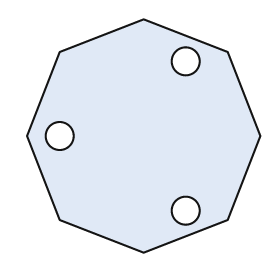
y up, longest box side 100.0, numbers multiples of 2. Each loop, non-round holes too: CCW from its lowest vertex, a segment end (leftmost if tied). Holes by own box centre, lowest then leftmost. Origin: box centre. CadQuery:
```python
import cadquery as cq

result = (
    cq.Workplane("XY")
    .moveTo(0.0, -50.0)
    .lineTo(36.0, -36.0)
    .lineTo(50.0, 0.0)
    .lineTo(36.0, 36.0)
    .lineTo(0.0, 50.0)
    .lineTo(-36.0, 36.0)
    .lineTo(-50.0, 0.0)
    .lineTo(-36.0, -36.0)
    .close()
    .moveTo(18.0, -32.0)
    .circle(6.0)
    .moveTo(-36.0, 0.0)
    .circle(6.0)
    .moveTo(18.0, 32.0)
    .circle(6.0)
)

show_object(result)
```